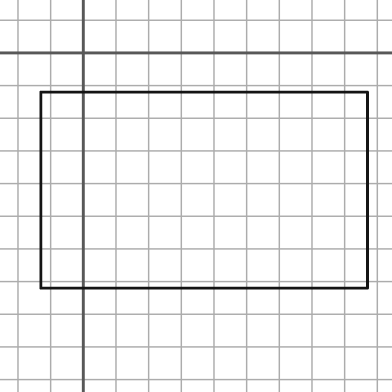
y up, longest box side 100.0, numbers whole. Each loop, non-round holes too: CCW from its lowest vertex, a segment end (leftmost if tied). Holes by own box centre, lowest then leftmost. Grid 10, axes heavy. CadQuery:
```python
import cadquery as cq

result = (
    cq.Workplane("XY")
    .moveTo(-13.0, -72.0)
    .lineTo(87.0, -72.0)
    .lineTo(87.0, -12.0)
    .lineTo(-13.0, -12.0)
    .close()
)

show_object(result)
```